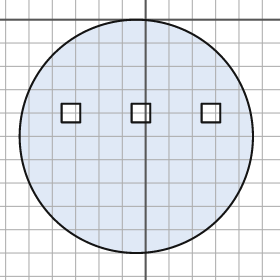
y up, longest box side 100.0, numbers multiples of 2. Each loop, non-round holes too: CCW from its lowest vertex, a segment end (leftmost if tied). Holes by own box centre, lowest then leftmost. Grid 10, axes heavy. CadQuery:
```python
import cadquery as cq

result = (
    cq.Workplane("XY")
    .moveTo(-4.0, -50.0)
    .circle(50.0)
    .moveTo(-36.0, -44.0)
    .lineTo(-28.0, -44.0)
    .lineTo(-28.0, -36.0)
    .lineTo(-36.0, -36.0)
    .close()
    .moveTo(-6.0, -44.0)
    .lineTo(2.0, -44.0)
    .lineTo(2.0, -36.0)
    .lineTo(-6.0, -36.0)
    .close()
    .moveTo(24.0, -44.0)
    .lineTo(32.0, -44.0)
    .lineTo(32.0, -36.0)
    .lineTo(24.0, -36.0)
    .close()
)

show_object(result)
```